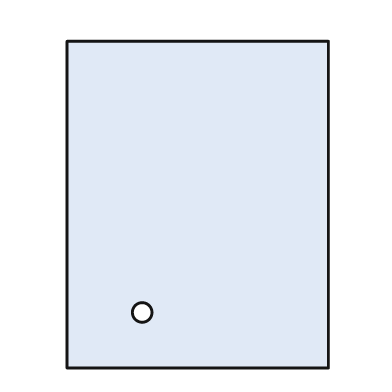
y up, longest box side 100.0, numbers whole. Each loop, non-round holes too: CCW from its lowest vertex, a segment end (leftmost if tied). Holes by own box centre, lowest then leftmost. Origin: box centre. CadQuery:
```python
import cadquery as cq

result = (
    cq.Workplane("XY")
    .moveTo(-40.0, -50.0)
    .lineTo(40.0, -50.0)
    .lineTo(40.0, 50.0)
    .lineTo(-40.0, 50.0)
    .close()
    .moveTo(-17.0, -33.0)
    .circle(3.0)
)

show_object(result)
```